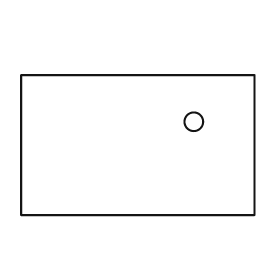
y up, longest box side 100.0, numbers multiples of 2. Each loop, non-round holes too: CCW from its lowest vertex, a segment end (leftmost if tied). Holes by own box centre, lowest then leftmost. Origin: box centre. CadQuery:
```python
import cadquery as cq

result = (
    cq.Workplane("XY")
    .moveTo(-50.0, -30.0)
    .lineTo(50.0, -30.0)
    .lineTo(50.0, 30.0)
    .lineTo(-50.0, 30.0)
    .close()
    .moveTo(24.0, 10.0)
    .circle(4.0)
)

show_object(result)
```